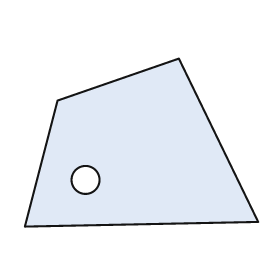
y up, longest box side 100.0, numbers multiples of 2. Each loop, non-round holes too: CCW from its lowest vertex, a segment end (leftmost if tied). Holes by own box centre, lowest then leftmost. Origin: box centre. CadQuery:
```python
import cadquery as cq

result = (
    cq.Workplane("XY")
    .moveTo(-50.0, -36.0)
    .lineTo(50.0, -34.0)
    .lineTo(16.0, 36.0)
    .lineTo(-36.0, 18.0)
    .close()
    .moveTo(-24.0, -16.0)
    .circle(6.0)
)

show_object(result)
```